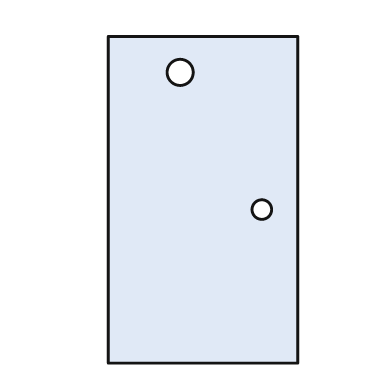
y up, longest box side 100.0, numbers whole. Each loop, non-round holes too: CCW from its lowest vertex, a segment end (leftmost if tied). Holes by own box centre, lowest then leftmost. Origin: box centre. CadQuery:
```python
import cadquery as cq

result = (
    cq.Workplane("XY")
    .moveTo(-29.0, -50.0)
    .lineTo(29.0, -50.0)
    .lineTo(29.0, 50.0)
    .lineTo(-29.0, 50.0)
    .close()
    .moveTo(18.0, -3.0)
    .circle(3.0)
    .moveTo(-7.0, 39.0)
    .circle(4.0)
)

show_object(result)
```